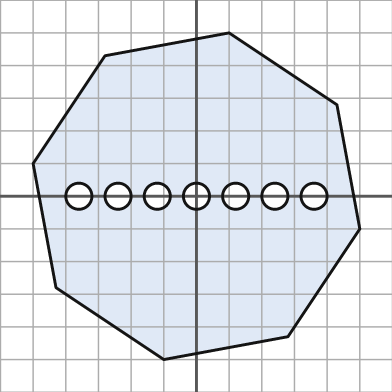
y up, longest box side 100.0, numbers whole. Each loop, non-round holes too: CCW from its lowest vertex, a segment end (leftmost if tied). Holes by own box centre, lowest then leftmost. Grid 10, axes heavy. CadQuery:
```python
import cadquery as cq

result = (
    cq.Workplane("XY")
    .moveTo(-10.0, -50.0)
    .lineTo(28.0, -43.0)
    .lineTo(50.0, -10.0)
    .lineTo(43.0, 28.0)
    .lineTo(10.0, 50.0)
    .lineTo(-28.0, 43.0)
    .lineTo(-50.0, 10.0)
    .lineTo(-43.0, -28.0)
    .close()
    .moveTo(-36.0, 0.0)
    .circle(4.0)
    .moveTo(-24.0, 0.0)
    .circle(4.0)
    .moveTo(-12.0, 0.0)
    .circle(4.0)
    .moveTo(0.0, 0.0)
    .circle(4.0)
    .moveTo(12.0, 0.0)
    .circle(4.0)
    .moveTo(24.0, 0.0)
    .circle(4.0)
    .moveTo(36.0, 0.0)
    .circle(4.0)
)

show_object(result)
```